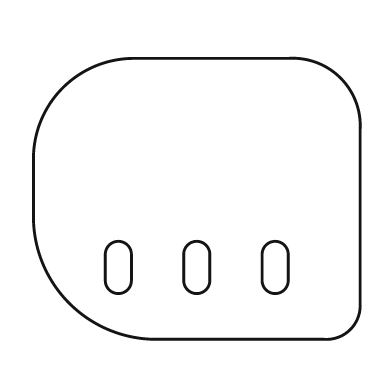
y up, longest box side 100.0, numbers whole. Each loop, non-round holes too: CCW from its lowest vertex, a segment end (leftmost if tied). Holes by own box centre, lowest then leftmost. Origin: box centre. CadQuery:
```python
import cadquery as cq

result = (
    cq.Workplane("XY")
    .moveTo(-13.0, -43.0)
    .lineTo(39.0, -43.0)
    .threePointArc((47.0, -40.0), (50.0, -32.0))
    .lineTo(50.0, 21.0)
    .threePointArc((44.0, 37.0), (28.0, 43.0))
    .lineTo(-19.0, 43.0)
    .threePointArc((-41.0, 34.0), (-50.0, 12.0))
    .lineTo(-50.0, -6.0)
    .threePointArc((-39.0, -32.0), (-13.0, -43.0))
    .close()
    .moveTo(-28.0, -25.0)
    .threePointArc((-24.0, -29.0), (-20.0, -25.0))
    .lineTo(-20.0, -17.0)
    .threePointArc((-24.0, -13.0), (-28.0, -17.0))
    .close()
    .moveTo(-4.0, -25.0)
    .threePointArc((0.0, -29.0), (4.0, -25.0))
    .lineTo(4.0, -17.0)
    .threePointArc((0.0, -13.0), (-4.0, -17.0))
    .close()
    .moveTo(20.0, -25.0)
    .threePointArc((24.0, -29.0), (28.0, -25.0))
    .lineTo(28.0, -17.0)
    .threePointArc((24.0, -13.0), (20.0, -17.0))
    .close()
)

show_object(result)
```